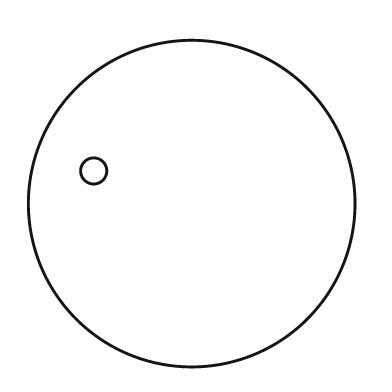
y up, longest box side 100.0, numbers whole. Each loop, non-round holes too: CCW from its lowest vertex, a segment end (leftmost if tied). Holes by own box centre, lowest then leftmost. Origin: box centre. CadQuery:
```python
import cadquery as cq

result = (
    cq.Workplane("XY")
    .moveTo(0.0, 0.0)
    .circle(50.0)
    .moveTo(-30.0, 10.0)
    .circle(4.0)
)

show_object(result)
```